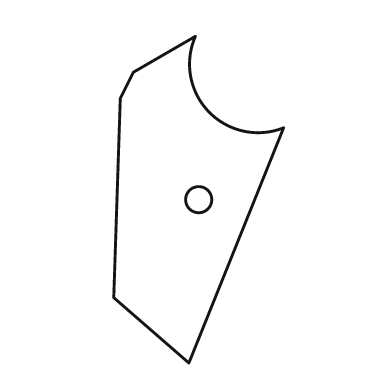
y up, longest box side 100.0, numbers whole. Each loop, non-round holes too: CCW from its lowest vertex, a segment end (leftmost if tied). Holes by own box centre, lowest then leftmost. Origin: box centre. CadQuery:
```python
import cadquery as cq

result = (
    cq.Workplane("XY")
    .moveTo(-3.0, -50.0)
    .lineTo(26.0, 22.0)
    .threePointArc((3.0, 27.0), (-1.0, 50.0))
    .lineTo(-20.0, 39.0)
    .lineTo(-24.0, 31.0)
    .lineTo(-26.0, -30.0)
    .close()
    .moveTo(0.0, 0.0)
    .circle(4.0)
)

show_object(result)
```